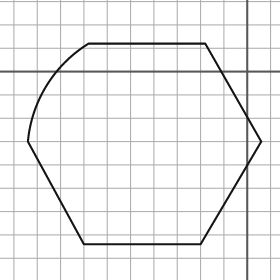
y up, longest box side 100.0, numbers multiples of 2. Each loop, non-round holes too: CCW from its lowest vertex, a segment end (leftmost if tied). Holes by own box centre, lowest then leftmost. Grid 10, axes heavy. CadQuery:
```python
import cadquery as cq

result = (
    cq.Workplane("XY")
    .moveTo(-70.0, -74.0)
    .lineTo(-20.0, -74.0)
    .lineTo(6.0, -30.0)
    .lineTo(-18.0, 12.0)
    .lineTo(-68.0, 12.0)
    .threePointArc((-86.0, -6.0), (-94.0, -30.0))
    .close()
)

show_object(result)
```